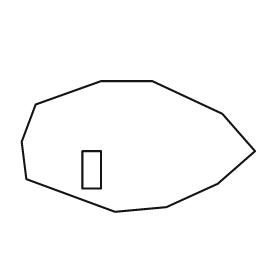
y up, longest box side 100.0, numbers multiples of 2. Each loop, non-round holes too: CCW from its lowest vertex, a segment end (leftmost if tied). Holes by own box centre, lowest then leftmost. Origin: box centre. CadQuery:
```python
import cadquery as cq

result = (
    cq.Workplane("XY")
    .moveTo(-10.0, -28.0)
    .lineTo(12.0, -26.0)
    .lineTo(34.0, -16.0)
    .lineTo(50.0, -2.0)
    .lineTo(36.0, 14.0)
    .lineTo(6.0, 28.0)
    .lineTo(-16.0, 28.0)
    .lineTo(-44.0, 18.0)
    .lineTo(-50.0, 2.0)
    .lineTo(-48.0, -14.0)
    .close()
    .moveTo(-24.0, -18.0)
    .lineTo(-16.0, -18.0)
    .lineTo(-16.0, -2.0)
    .lineTo(-24.0, -2.0)
    .close()
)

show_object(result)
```